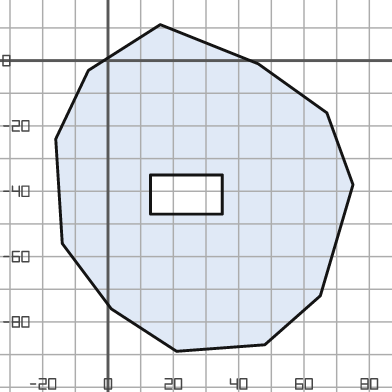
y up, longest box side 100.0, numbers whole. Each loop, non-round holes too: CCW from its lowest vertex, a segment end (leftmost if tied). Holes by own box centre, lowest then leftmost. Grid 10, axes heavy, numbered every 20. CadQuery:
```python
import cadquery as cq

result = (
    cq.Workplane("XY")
    .moveTo(21.0, -89.0)
    .lineTo(48.0, -87.0)
    .lineTo(65.0, -72.0)
    .lineTo(75.0, -38.0)
    .lineTo(67.0, -16.0)
    .lineTo(46.0, -1.0)
    .lineTo(16.0, 11.0)
    .lineTo(-6.0, -3.0)
    .lineTo(-16.0, -24.0)
    .lineTo(-14.0, -56.0)
    .lineTo(1.0, -76.0)
    .close()
    .moveTo(13.0, -47.0)
    .lineTo(35.0, -47.0)
    .lineTo(35.0, -35.0)
    .lineTo(13.0, -35.0)
    .close()
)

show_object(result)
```